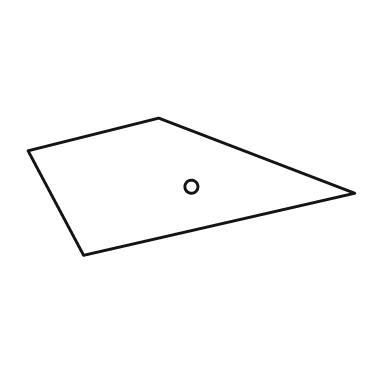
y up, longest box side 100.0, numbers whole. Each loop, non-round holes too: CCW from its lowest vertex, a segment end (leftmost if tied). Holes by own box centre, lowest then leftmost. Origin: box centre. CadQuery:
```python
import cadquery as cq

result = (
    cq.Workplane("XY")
    .moveTo(-33.0, -21.0)
    .lineTo(50.0, -2.0)
    .lineTo(-10.0, 21.0)
    .lineTo(-50.0, 11.0)
    .close()
    .moveTo(0.0, 0.0)
    .circle(2.0)
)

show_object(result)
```